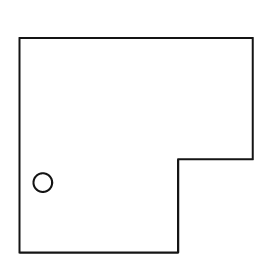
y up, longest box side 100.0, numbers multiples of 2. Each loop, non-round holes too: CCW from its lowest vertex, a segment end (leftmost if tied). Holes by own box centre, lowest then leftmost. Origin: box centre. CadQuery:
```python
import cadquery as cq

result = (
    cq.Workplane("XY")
    .moveTo(-50.0, -46.0)
    .lineTo(18.0, -46.0)
    .lineTo(18.0, -6.0)
    .lineTo(50.0, -6.0)
    .lineTo(50.0, 46.0)
    .lineTo(-50.0, 46.0)
    .close()
    .moveTo(-40.0, -16.0)
    .circle(4.0)
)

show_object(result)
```